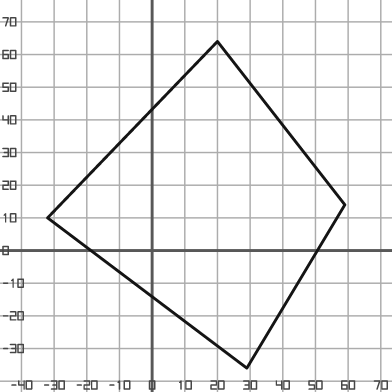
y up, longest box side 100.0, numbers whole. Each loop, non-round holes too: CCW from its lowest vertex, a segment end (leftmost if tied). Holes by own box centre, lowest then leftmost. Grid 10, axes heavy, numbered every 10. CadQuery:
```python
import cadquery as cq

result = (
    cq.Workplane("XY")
    .moveTo(29.0, -36.0)
    .lineTo(59.0, 14.0)
    .lineTo(20.0, 64.0)
    .lineTo(-32.0, 10.0)
    .close()
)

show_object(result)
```